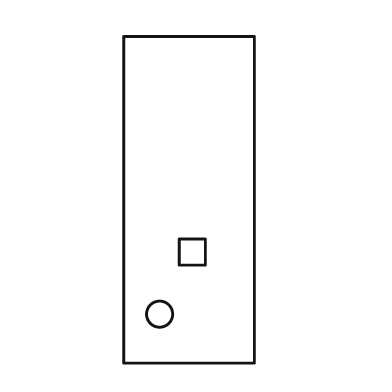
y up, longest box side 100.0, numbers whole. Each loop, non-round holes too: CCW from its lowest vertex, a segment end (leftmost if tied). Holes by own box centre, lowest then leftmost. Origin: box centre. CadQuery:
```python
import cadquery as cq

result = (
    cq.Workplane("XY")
    .moveTo(-20.0, -50.0)
    .lineTo(20.0, -50.0)
    .lineTo(20.0, 50.0)
    .lineTo(-20.0, 50.0)
    .close()
    .moveTo(-9.0, -35.0)
    .circle(4.0)
    .moveTo(-3.0, -20.0)
    .lineTo(5.0, -20.0)
    .lineTo(5.0, -12.0)
    .lineTo(-3.0, -12.0)
    .close()
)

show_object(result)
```